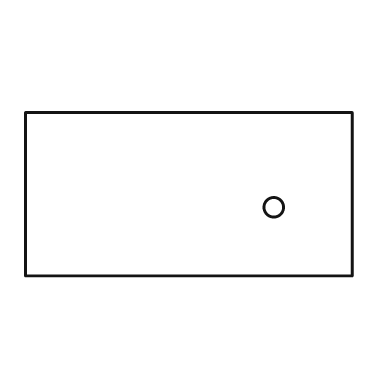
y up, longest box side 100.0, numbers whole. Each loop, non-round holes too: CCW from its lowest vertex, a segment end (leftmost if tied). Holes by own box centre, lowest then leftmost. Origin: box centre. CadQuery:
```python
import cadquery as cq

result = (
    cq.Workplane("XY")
    .moveTo(-50.0, -25.0)
    .lineTo(50.0, -25.0)
    .lineTo(50.0, 25.0)
    .lineTo(-50.0, 25.0)
    .close()
    .moveTo(26.0, -4.0)
    .circle(3.0)
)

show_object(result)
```